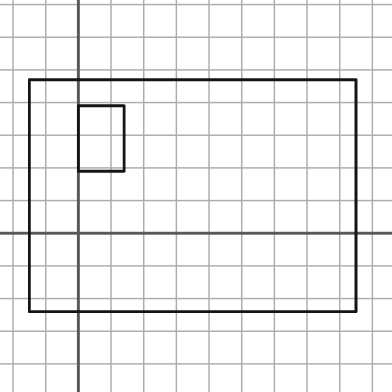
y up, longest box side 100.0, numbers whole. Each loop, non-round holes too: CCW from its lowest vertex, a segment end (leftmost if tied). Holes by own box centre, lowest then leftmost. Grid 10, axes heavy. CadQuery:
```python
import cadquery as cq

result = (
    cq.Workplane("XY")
    .moveTo(-15.0, -24.0)
    .lineTo(85.0, -24.0)
    .lineTo(85.0, 47.0)
    .lineTo(-15.0, 47.0)
    .close()
    .moveTo(0.0, 19.0)
    .lineTo(14.0, 19.0)
    .lineTo(14.0, 39.0)
    .lineTo(0.0, 39.0)
    .close()
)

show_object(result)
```